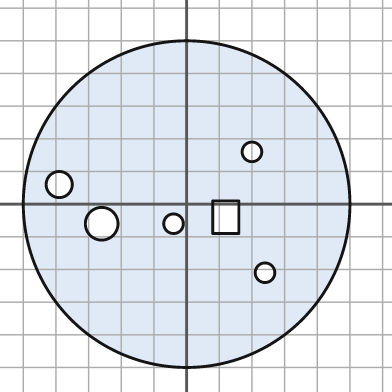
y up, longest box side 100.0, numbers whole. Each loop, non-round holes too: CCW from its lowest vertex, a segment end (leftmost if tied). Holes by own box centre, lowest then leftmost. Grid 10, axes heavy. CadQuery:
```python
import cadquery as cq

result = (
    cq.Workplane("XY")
    .moveTo(0.0, 0.0)
    .circle(50.0)
    .moveTo(24.0, -21.0)
    .circle(3.0)
    .moveTo(-26.0, -6.0)
    .circle(5.0)
    .moveTo(-4.0, -6.0)
    .circle(3.0)
    .moveTo(8.0, -9.0)
    .lineTo(16.0, -9.0)
    .lineTo(16.0, 1.0)
    .lineTo(8.0, 1.0)
    .close()
    .moveTo(-39.0, 6.0)
    .circle(4.0)
    .moveTo(20.0, 16.0)
    .circle(3.0)
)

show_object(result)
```